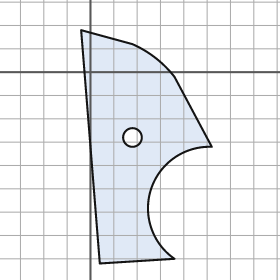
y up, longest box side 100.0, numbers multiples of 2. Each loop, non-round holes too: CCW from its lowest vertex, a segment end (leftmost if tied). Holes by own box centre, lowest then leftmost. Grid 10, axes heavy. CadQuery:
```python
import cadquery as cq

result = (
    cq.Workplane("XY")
    .moveTo(4.0, -82.0)
    .lineTo(36.0, -80.0)
    .threePointArc((26.0, -50.0), (52.0, -32.0))
    .lineTo(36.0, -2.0)
    .threePointArc((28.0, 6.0), (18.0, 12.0))
    .lineTo(-4.0, 18.0)
    .close()
    .moveTo(18.0, -28.0)
    .circle(4.0)
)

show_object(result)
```